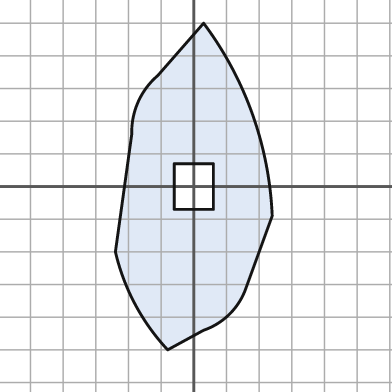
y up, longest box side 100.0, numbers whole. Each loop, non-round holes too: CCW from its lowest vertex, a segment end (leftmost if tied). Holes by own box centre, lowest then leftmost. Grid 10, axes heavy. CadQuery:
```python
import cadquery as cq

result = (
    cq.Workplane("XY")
    .moveTo(-8.0, -50.0)
    .lineTo(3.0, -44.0)
    .threePointArc((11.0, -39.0), (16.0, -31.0))
    .lineTo(24.0, -9.0)
    .threePointArc((18.0, 22.0), (3.0, 50.0))
    .lineTo(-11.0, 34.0)
    .threePointArc((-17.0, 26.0), (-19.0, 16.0))
    .lineTo(-24.0, -20.0)
    .threePointArc((-18.0, -36.0), (-8.0, -50.0))
    .close()
    .moveTo(-6.0, -7.0)
    .lineTo(6.0, -7.0)
    .lineTo(6.0, 7.0)
    .lineTo(-6.0, 7.0)
    .close()
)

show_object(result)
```